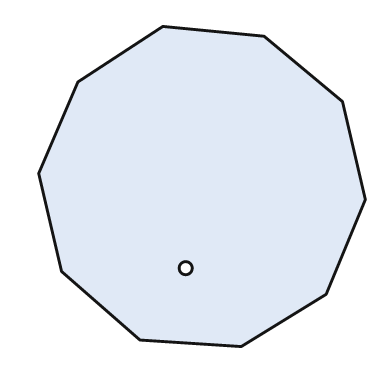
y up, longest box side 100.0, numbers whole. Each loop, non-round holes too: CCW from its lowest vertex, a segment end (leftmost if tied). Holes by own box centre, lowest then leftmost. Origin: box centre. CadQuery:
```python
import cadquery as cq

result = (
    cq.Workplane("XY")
    .moveTo(12.0, -49.0)
    .lineTo(38.0, -33.0)
    .lineTo(50.0, -4.0)
    .lineTo(43.0, 26.0)
    .lineTo(19.0, 46.0)
    .lineTo(-12.0, 49.0)
    .lineTo(-38.0, 32.0)
    .lineTo(-50.0, 4.0)
    .lineTo(-43.0, -26.0)
    .lineTo(-19.0, -47.0)
    .close()
    .moveTo(-5.0, -25.0)
    .circle(2.0)
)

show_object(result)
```